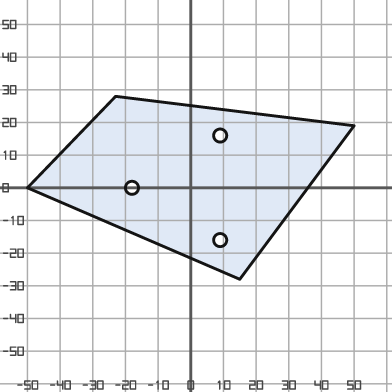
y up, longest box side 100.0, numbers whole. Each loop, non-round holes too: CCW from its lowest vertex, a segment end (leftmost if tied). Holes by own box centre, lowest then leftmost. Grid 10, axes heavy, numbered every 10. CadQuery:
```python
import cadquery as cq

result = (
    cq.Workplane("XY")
    .moveTo(15.0, -28.0)
    .lineTo(50.0, 19.0)
    .lineTo(-23.0, 28.0)
    .lineTo(-50.0, 0.0)
    .close()
    .moveTo(9.0, -16.0)
    .circle(2.0)
    .moveTo(-18.0, 0.0)
    .circle(2.0)
    .moveTo(9.0, 16.0)
    .circle(2.0)
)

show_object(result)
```